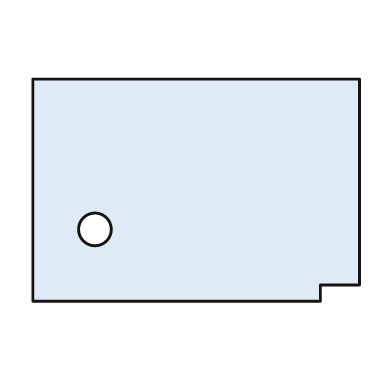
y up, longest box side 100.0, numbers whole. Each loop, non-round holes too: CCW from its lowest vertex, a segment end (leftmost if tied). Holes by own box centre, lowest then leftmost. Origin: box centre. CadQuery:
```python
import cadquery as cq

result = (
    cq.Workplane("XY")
    .moveTo(-50.0, -34.0)
    .lineTo(38.0, -34.0)
    .lineTo(38.0, -29.0)
    .lineTo(50.0, -29.0)
    .lineTo(50.0, 34.0)
    .lineTo(-50.0, 34.0)
    .close()
    .moveTo(-31.0, -12.0)
    .circle(5.0)
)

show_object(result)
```